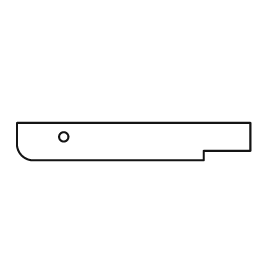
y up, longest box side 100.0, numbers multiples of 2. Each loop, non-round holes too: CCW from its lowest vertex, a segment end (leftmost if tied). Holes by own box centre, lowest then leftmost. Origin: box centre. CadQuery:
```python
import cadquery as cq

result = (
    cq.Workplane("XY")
    .moveTo(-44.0, -8.0)
    .lineTo(30.0, -8.0)
    .lineTo(30.0, -4.0)
    .lineTo(50.0, -4.0)
    .lineTo(50.0, 8.0)
    .lineTo(-50.0, 8.0)
    .lineTo(-50.0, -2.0)
    .threePointArc((-48.0, -6.0), (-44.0, -8.0))
    .close()
    .moveTo(-30.0, 2.0)
    .circle(2.0)
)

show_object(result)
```